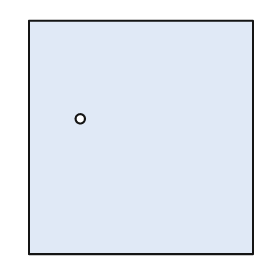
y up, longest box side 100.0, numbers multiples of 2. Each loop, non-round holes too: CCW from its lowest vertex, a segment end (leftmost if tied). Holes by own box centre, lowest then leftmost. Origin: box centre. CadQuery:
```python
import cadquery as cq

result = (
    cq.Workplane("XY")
    .moveTo(-48.0, -50.0)
    .lineTo(48.0, -50.0)
    .lineTo(48.0, 50.0)
    .lineTo(-48.0, 50.0)
    .close()
    .moveTo(-26.0, 8.0)
    .circle(2.0)
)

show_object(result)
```